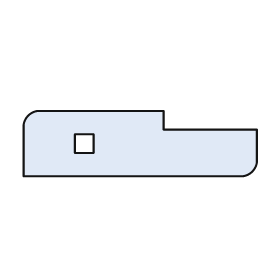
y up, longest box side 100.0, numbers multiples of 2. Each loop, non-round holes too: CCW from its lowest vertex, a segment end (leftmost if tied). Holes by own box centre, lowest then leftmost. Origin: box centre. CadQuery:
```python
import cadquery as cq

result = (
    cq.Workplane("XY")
    .moveTo(-50.0, -14.0)
    .lineTo(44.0, -14.0)
    .threePointArc((48.0, -12.0), (50.0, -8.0))
    .lineTo(50.0, 6.0)
    .lineTo(10.0, 6.0)
    .lineTo(10.0, 14.0)
    .lineTo(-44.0, 14.0)
    .threePointArc((-48.0, 12.0), (-50.0, 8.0))
    .close()
    .moveTo(-28.0, -4.0)
    .lineTo(-20.0, -4.0)
    .lineTo(-20.0, 4.0)
    .lineTo(-28.0, 4.0)
    .close()
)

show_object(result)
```